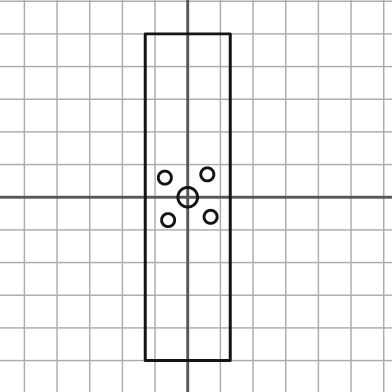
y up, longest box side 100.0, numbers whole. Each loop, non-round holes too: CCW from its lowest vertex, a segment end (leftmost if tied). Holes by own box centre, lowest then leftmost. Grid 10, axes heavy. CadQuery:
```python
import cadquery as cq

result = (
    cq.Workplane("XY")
    .moveTo(-13.0, -50.0)
    .lineTo(13.0, -50.0)
    .lineTo(13.0, 50.0)
    .lineTo(-13.0, 50.0)
    .close()
    .moveTo(-6.0, -7.0)
    .circle(2.0)
    .moveTo(7.0, -6.0)
    .circle(2.0)
    .moveTo(0.0, 0.0)
    .circle(3.0)
    .moveTo(-7.0, 6.0)
    .circle(2.0)
    .moveTo(6.0, 7.0)
    .circle(2.0)
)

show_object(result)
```